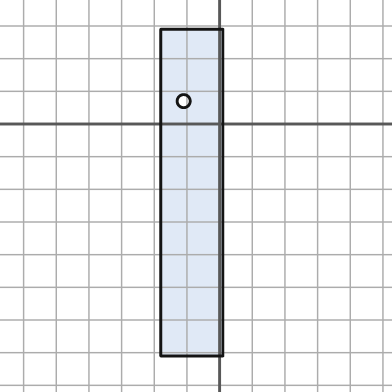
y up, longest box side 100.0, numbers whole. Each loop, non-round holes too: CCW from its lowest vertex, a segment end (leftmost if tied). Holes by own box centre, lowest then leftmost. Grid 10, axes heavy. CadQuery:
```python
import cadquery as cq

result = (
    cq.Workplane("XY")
    .moveTo(-18.0, -71.0)
    .lineTo(1.0, -71.0)
    .lineTo(1.0, 29.0)
    .lineTo(-18.0, 29.0)
    .close()
    .moveTo(-11.0, 7.0)
    .circle(2.0)
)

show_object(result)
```